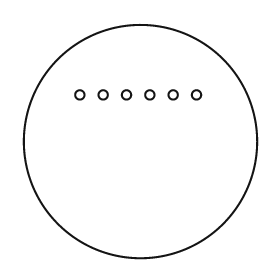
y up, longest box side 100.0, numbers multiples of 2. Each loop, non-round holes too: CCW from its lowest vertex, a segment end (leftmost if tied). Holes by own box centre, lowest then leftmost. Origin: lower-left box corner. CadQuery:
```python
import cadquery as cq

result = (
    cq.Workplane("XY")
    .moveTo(50.0, 50.0)
    .circle(50.0)
    .moveTo(24.0, 70.0)
    .circle(2.0)
    .moveTo(34.0, 70.0)
    .circle(2.0)
    .moveTo(44.0, 70.0)
    .circle(2.0)
    .moveTo(54.0, 70.0)
    .circle(2.0)
    .moveTo(64.0, 70.0)
    .circle(2.0)
    .moveTo(74.0, 70.0)
    .circle(2.0)
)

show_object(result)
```